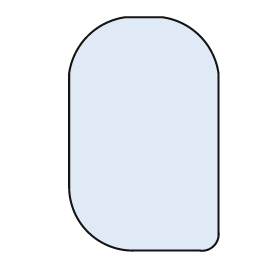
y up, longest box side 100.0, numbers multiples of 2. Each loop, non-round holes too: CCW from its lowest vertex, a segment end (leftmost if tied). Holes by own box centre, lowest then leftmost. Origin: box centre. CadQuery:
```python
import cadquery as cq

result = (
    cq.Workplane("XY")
    .moveTo(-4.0, -50.0)
    .lineTo(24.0, -50.0)
    .threePointArc((30.0, -48.0), (32.0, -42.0))
    .lineTo(32.0, 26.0)
    .threePointArc((24.0, 42.0), (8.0, 50.0))
    .lineTo(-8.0, 50.0)
    .threePointArc((-24.0, 42.0), (-32.0, 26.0))
    .lineTo(-32.0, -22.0)
    .threePointArc((-24.0, -42.0), (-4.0, -50.0))
    .close()
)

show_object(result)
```